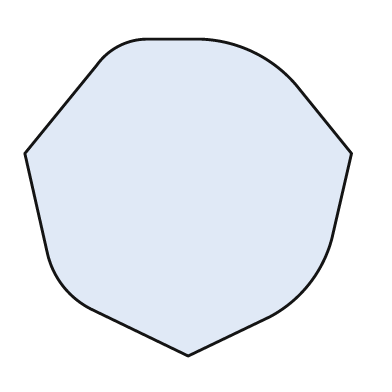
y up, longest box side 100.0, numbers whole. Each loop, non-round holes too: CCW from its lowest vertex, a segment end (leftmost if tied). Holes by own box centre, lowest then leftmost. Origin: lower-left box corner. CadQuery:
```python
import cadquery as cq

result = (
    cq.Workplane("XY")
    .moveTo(50.0, 0.0)
    .lineTo(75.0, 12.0)
    .threePointArc((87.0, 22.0), (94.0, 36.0))
    .lineTo(100.0, 62.0)
    .lineTo(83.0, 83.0)
    .threePointArc((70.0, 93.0), (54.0, 97.0))
    .lineTo(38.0, 97.0)
    .threePointArc((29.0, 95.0), (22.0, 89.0))
    .lineTo(0.0, 62.0)
    .lineTo(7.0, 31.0)
    .threePointArc((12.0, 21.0), (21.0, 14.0))
    .close()
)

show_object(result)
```